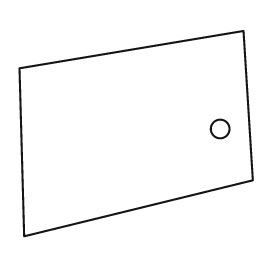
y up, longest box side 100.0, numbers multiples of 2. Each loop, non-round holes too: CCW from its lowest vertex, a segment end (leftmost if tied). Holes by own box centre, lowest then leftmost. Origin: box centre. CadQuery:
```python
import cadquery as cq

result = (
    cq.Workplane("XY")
    .moveTo(-48.0, -44.0)
    .lineTo(50.0, -20.0)
    .lineTo(46.0, 44.0)
    .lineTo(-50.0, 28.0)
    .close()
    .moveTo(36.0, 2.0)
    .circle(4.0)
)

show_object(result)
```